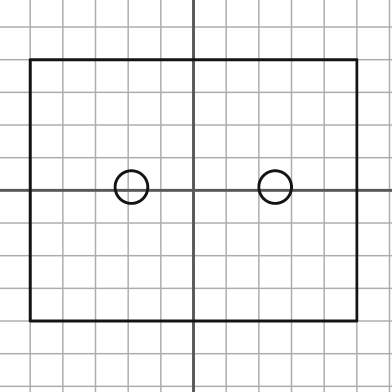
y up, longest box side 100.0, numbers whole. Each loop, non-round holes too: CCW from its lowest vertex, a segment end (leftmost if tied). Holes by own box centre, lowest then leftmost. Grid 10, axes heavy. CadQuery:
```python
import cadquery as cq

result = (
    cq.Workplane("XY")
    .moveTo(-50.0, -40.0)
    .lineTo(50.0, -40.0)
    .lineTo(50.0, 40.0)
    .lineTo(-50.0, 40.0)
    .close()
    .moveTo(-19.0, 1.0)
    .circle(5.0)
    .moveTo(25.0, 1.0)
    .circle(5.0)
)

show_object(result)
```